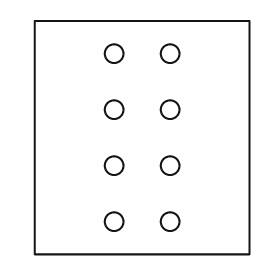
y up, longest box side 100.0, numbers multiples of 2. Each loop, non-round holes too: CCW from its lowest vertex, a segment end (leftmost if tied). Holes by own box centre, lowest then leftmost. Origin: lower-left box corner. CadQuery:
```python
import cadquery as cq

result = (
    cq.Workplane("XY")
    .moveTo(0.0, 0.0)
    .lineTo(92.0, 0.0)
    .lineTo(92.0, 100.0)
    .lineTo(0.0, 100.0)
    .close()
    .moveTo(34.0, 14.0)
    .circle(4.0)
    .moveTo(58.0, 14.0)
    .circle(4.0)
    .moveTo(34.0, 38.0)
    .circle(4.0)
    .moveTo(58.0, 38.0)
    .circle(4.0)
    .moveTo(34.0, 62.0)
    .circle(4.0)
    .moveTo(58.0, 62.0)
    .circle(4.0)
    .moveTo(34.0, 86.0)
    .circle(4.0)
    .moveTo(58.0, 86.0)
    .circle(4.0)
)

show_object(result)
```